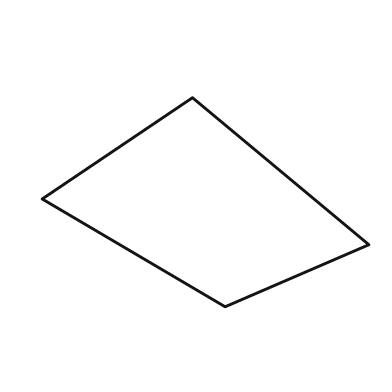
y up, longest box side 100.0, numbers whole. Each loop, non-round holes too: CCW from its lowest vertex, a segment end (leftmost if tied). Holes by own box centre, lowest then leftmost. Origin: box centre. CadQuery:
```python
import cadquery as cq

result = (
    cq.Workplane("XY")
    .moveTo(6.0, -32.0)
    .lineTo(50.0, -13.0)
    .lineTo(-4.0, 32.0)
    .lineTo(-50.0, 1.0)
    .close()
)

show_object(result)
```